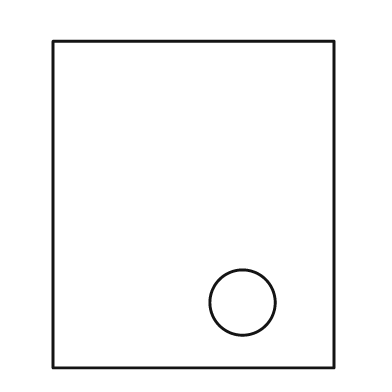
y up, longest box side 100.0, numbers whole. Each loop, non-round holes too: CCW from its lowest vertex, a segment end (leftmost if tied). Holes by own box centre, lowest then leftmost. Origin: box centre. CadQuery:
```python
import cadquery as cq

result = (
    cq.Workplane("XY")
    .moveTo(-43.0, -50.0)
    .lineTo(43.0, -50.0)
    .lineTo(43.0, 50.0)
    .lineTo(-43.0, 50.0)
    .close()
    .moveTo(15.0, -30.0)
    .circle(10.0)
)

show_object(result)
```